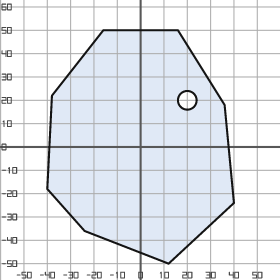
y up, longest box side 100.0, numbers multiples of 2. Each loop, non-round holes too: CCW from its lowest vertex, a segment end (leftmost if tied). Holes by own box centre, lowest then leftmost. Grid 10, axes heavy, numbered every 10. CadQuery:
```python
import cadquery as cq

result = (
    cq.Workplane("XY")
    .moveTo(12.0, -50.0)
    .lineTo(40.0, -24.0)
    .lineTo(36.0, 18.0)
    .lineTo(16.0, 50.0)
    .lineTo(-16.0, 50.0)
    .lineTo(-38.0, 22.0)
    .lineTo(-40.0, -18.0)
    .lineTo(-24.0, -36.0)
    .close()
    .moveTo(20.0, 20.0)
    .circle(4.0)
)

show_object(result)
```